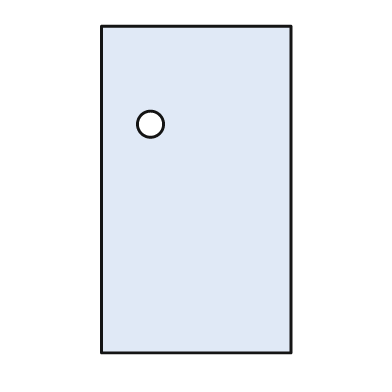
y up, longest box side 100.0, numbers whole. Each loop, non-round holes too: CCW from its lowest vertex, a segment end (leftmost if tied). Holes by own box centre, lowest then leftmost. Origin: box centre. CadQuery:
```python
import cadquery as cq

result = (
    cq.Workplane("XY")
    .moveTo(-29.0, -50.0)
    .lineTo(29.0, -50.0)
    .lineTo(29.0, 50.0)
    .lineTo(-29.0, 50.0)
    .close()
    .moveTo(-14.0, 20.0)
    .circle(4.0)
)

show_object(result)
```